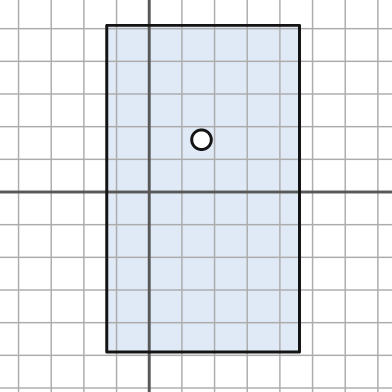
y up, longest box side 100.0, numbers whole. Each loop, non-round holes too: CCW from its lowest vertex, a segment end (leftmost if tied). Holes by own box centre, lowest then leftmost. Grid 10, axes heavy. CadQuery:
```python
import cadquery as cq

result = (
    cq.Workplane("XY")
    .moveTo(-13.0, -49.0)
    .lineTo(46.0, -49.0)
    .lineTo(46.0, 51.0)
    .lineTo(-13.0, 51.0)
    .close()
    .moveTo(16.0, 16.0)
    .circle(3.0)
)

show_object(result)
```